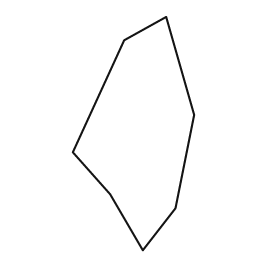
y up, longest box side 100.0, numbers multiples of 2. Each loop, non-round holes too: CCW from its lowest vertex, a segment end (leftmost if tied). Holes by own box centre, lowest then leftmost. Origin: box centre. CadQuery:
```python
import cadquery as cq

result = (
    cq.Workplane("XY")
    .moveTo(4.0, -50.0)
    .lineTo(18.0, -32.0)
    .lineTo(26.0, 8.0)
    .lineTo(14.0, 50.0)
    .lineTo(-4.0, 40.0)
    .lineTo(-26.0, -8.0)
    .lineTo(-10.0, -26.0)
    .close()
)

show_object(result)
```